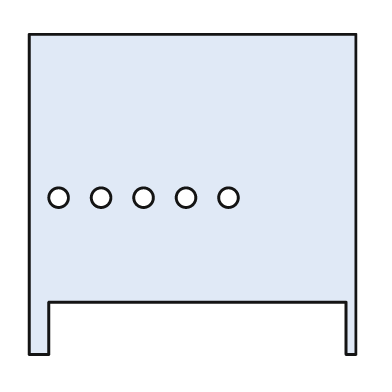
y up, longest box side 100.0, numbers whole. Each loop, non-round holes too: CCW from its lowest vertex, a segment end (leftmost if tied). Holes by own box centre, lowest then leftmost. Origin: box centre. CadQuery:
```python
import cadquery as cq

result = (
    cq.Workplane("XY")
    .moveTo(-50.0, -49.0)
    .lineTo(-44.0, -49.0)
    .lineTo(-44.0, -33.0)
    .lineTo(47.0, -33.0)
    .lineTo(47.0, -49.0)
    .lineTo(50.0, -49.0)
    .lineTo(50.0, 49.0)
    .lineTo(-50.0, 49.0)
    .close()
    .moveTo(-41.0, -1.0)
    .circle(3.0)
    .moveTo(-28.0, -1.0)
    .circle(3.0)
    .moveTo(-15.0, -1.0)
    .circle(3.0)
    .moveTo(-2.0, -1.0)
    .circle(3.0)
    .moveTo(11.0, -1.0)
    .circle(3.0)
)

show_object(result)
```